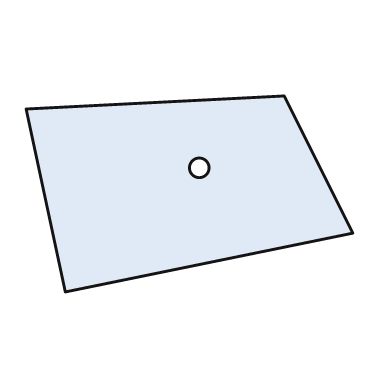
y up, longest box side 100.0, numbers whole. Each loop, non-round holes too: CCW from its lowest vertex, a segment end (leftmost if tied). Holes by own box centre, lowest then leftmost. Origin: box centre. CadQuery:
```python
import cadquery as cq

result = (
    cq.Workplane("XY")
    .moveTo(-38.0, -30.0)
    .lineTo(50.0, -12.0)
    .lineTo(29.0, 30.0)
    .lineTo(-50.0, 26.0)
    .close()
    .moveTo(3.0, 8.0)
    .circle(3.0)
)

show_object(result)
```